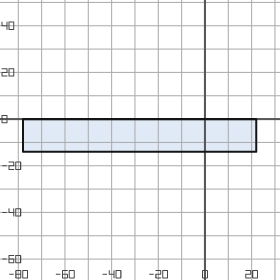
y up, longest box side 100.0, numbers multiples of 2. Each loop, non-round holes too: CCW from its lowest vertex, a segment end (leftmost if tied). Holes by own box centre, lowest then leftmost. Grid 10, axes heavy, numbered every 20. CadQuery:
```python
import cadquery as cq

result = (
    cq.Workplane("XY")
    .moveTo(-78.0, -14.0)
    .lineTo(22.0, -14.0)
    .lineTo(22.0, 0.0)
    .lineTo(-78.0, 0.0)
    .close()
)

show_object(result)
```